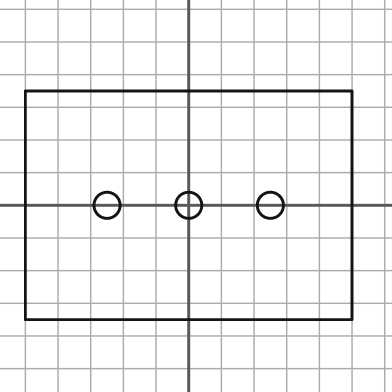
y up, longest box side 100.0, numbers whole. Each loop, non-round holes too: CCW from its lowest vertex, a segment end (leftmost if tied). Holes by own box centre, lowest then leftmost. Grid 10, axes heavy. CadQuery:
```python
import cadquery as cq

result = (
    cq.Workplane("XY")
    .moveTo(-50.0, -35.0)
    .lineTo(50.0, -35.0)
    .lineTo(50.0, 35.0)
    .lineTo(-50.0, 35.0)
    .close()
    .moveTo(-25.0, 0.0)
    .circle(4.0)
    .moveTo(0.0, 0.0)
    .circle(4.0)
    .moveTo(25.0, 0.0)
    .circle(4.0)
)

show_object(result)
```